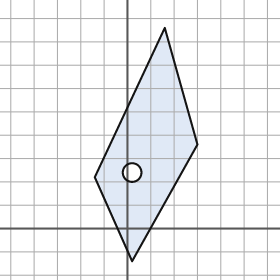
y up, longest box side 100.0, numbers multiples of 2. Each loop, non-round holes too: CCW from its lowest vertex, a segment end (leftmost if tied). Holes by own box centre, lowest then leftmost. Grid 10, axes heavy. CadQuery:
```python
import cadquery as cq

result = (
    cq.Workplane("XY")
    .moveTo(2.0, -14.0)
    .lineTo(30.0, 36.0)
    .lineTo(16.0, 86.0)
    .lineTo(-14.0, 22.0)
    .close()
    .moveTo(2.0, 24.0)
    .circle(4.0)
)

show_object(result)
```